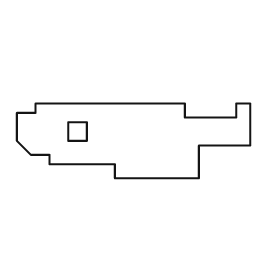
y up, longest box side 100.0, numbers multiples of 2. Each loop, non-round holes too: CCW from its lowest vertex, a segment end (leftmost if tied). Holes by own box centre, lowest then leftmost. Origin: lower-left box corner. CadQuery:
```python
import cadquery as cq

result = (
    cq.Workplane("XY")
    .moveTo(42.0, 0.0)
    .lineTo(78.0, 0.0)
    .lineTo(78.0, 14.0)
    .lineTo(100.0, 14.0)
    .lineTo(100.0, 32.0)
    .lineTo(94.0, 32.0)
    .lineTo(94.0, 26.0)
    .lineTo(72.0, 26.0)
    .lineTo(72.0, 32.0)
    .lineTo(8.0, 32.0)
    .lineTo(8.0, 28.0)
    .lineTo(0.0, 28.0)
    .lineTo(0.0, 16.0)
    .lineTo(6.0, 10.0)
    .lineTo(14.0, 10.0)
    .lineTo(14.0, 6.0)
    .lineTo(42.0, 6.0)
    .close()
    .moveTo(22.0, 16.0)
    .lineTo(30.0, 16.0)
    .lineTo(30.0, 24.0)
    .lineTo(22.0, 24.0)
    .close()
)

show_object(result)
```